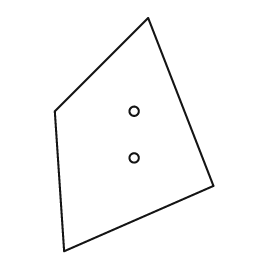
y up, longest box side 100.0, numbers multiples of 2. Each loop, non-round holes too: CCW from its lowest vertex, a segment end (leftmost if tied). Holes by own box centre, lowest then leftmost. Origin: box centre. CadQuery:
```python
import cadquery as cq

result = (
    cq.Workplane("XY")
    .moveTo(-30.0, -50.0)
    .lineTo(34.0, -22.0)
    .lineTo(6.0, 50.0)
    .lineTo(-34.0, 10.0)
    .close()
    .moveTo(0.0, -10.0)
    .circle(2.0)
    .moveTo(0.0, 10.0)
    .circle(2.0)
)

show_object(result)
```